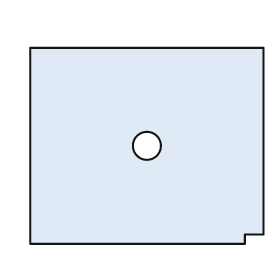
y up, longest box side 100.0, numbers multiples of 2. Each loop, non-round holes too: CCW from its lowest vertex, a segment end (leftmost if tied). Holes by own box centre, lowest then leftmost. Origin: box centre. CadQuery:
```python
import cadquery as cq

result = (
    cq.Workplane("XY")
    .moveTo(-50.0, -42.0)
    .lineTo(42.0, -42.0)
    .lineTo(42.0, -38.0)
    .lineTo(50.0, -38.0)
    .lineTo(50.0, 42.0)
    .lineTo(-50.0, 42.0)
    .close()
    .moveTo(0.0, 0.0)
    .circle(6.0)
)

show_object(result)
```